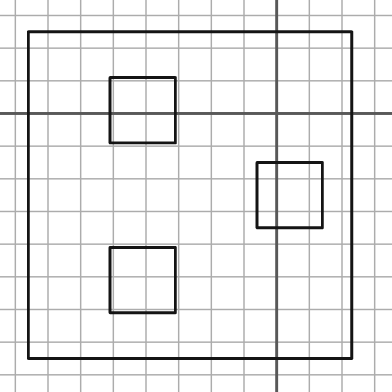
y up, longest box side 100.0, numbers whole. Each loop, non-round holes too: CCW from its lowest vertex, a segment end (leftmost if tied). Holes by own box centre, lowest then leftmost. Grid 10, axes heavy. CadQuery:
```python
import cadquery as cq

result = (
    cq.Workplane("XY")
    .moveTo(-76.0, -75.0)
    .lineTo(23.0, -75.0)
    .lineTo(23.0, 25.0)
    .lineTo(-76.0, 25.0)
    .close()
    .moveTo(-51.0, -61.0)
    .lineTo(-31.0, -61.0)
    .lineTo(-31.0, -41.0)
    .lineTo(-51.0, -41.0)
    .close()
    .moveTo(-6.0, -35.0)
    .lineTo(14.0, -35.0)
    .lineTo(14.0, -15.0)
    .lineTo(-6.0, -15.0)
    .close()
    .moveTo(-51.0, -9.0)
    .lineTo(-31.0, -9.0)
    .lineTo(-31.0, 11.0)
    .lineTo(-51.0, 11.0)
    .close()
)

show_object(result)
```